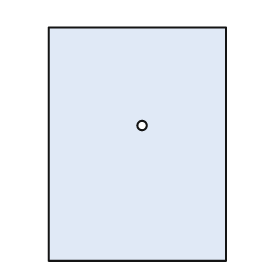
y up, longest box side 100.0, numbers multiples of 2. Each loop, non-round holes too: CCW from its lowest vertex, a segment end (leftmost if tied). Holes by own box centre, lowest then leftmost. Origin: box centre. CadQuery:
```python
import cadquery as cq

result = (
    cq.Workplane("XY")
    .moveTo(-38.0, -50.0)
    .lineTo(38.0, -50.0)
    .lineTo(38.0, 50.0)
    .lineTo(-38.0, 50.0)
    .close()
    .moveTo(2.0, 8.0)
    .circle(2.0)
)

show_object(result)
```